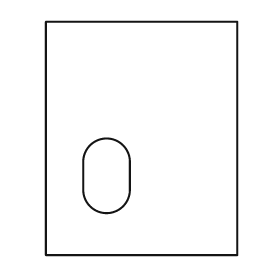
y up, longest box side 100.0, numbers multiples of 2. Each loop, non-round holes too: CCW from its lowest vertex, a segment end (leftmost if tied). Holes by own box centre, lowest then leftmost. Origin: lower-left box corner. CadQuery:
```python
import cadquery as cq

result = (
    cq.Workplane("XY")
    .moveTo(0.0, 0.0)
    .lineTo(82.0, 0.0)
    .lineTo(82.0, 100.0)
    .lineTo(0.0, 100.0)
    .close()
    .moveTo(16.0, 28.0)
    .threePointArc((26.0, 18.0), (36.0, 28.0))
    .lineTo(36.0, 40.0)
    .threePointArc((26.0, 50.0), (16.0, 40.0))
    .close()
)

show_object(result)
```